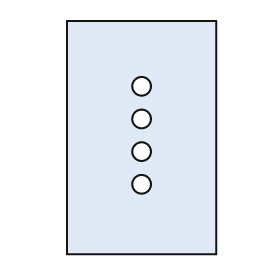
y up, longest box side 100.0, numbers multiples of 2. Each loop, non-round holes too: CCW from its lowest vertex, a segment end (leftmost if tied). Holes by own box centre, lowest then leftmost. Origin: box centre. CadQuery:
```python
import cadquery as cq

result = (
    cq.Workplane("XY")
    .moveTo(-32.0, -50.0)
    .lineTo(32.0, -50.0)
    .lineTo(32.0, 50.0)
    .lineTo(-32.0, 50.0)
    .close()
    .moveTo(0.0, -20.0)
    .circle(4.0)
    .moveTo(0.0, -6.0)
    .circle(4.0)
    .moveTo(0.0, 8.0)
    .circle(4.0)
    .moveTo(0.0, 22.0)
    .circle(4.0)
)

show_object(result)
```